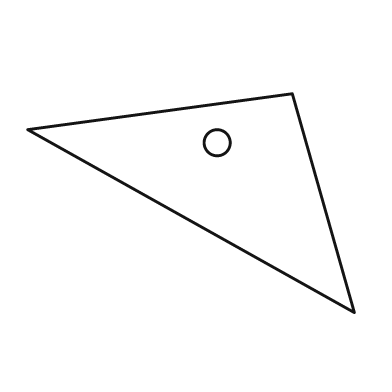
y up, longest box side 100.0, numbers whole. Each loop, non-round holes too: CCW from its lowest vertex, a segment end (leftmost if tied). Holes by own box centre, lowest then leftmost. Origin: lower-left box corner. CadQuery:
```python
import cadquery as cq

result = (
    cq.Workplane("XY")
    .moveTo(100.0, 0.0)
    .lineTo(81.0, 67.0)
    .lineTo(0.0, 56.0)
    .close()
    .moveTo(58.0, 52.0)
    .circle(4.0)
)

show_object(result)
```